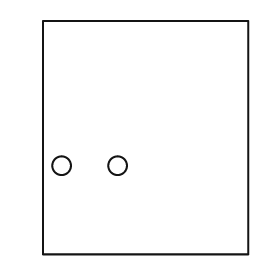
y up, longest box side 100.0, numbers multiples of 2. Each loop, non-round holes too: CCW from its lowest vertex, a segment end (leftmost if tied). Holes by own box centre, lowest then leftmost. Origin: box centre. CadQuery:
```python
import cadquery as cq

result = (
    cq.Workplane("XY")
    .moveTo(-44.0, -50.0)
    .lineTo(44.0, -50.0)
    .lineTo(44.0, 50.0)
    .lineTo(-44.0, 50.0)
    .close()
    .moveTo(-36.0, -12.0)
    .circle(4.0)
    .moveTo(-12.0, -12.0)
    .circle(4.0)
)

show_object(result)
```